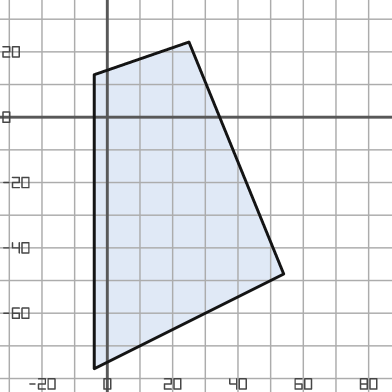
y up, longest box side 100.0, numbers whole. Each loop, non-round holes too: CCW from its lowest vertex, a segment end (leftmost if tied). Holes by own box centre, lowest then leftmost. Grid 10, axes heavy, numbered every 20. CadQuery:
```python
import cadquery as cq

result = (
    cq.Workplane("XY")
    .moveTo(-4.0, -77.0)
    .lineTo(54.0, -48.0)
    .lineTo(25.0, 23.0)
    .lineTo(-4.0, 13.0)
    .close()
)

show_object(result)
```